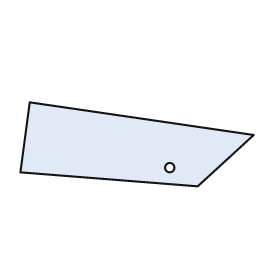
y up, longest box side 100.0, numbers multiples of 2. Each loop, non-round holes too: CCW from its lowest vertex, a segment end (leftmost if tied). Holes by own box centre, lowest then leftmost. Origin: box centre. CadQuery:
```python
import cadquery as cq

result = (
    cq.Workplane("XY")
    .moveTo(26.0, -18.0)
    .lineTo(50.0, 4.0)
    .lineTo(-46.0, 18.0)
    .lineTo(-50.0, -12.0)
    .close()
    .moveTo(14.0, -10.0)
    .circle(2.0)
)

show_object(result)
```